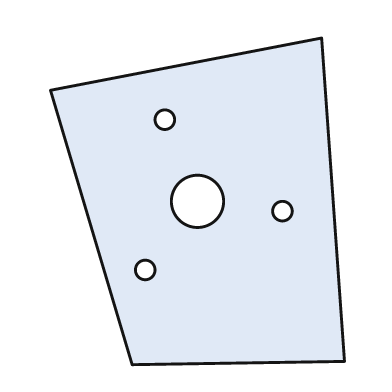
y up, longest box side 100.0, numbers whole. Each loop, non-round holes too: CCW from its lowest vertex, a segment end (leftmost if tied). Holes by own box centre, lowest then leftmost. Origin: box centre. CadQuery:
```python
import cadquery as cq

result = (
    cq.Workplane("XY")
    .moveTo(-20.0, -50.0)
    .lineTo(45.0, -49.0)
    .lineTo(38.0, 50.0)
    .lineTo(-45.0, 34.0)
    .close()
    .moveTo(-16.0, -21.0)
    .circle(3.0)
    .moveTo(26.0, -3.0)
    .circle(3.0)
    .moveTo(0.0, 0.0)
    .circle(8.0)
    .moveTo(-10.0, 25.0)
    .circle(3.0)
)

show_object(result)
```